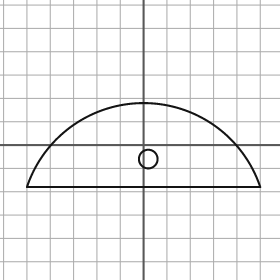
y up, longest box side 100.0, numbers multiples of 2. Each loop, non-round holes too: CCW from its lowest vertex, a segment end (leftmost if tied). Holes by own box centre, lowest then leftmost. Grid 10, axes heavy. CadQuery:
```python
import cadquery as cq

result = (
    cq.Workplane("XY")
    .moveTo(-50.0, -18.0)
    .lineTo(50.0, -18.0)
    .threePointArc((0.0, 18.0), (-50.0, -18.0))
    .close()
    .moveTo(2.0, -6.0)
    .circle(4.0)
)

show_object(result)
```